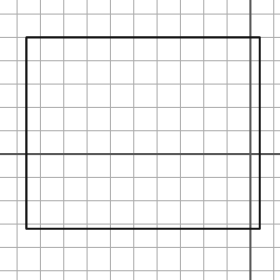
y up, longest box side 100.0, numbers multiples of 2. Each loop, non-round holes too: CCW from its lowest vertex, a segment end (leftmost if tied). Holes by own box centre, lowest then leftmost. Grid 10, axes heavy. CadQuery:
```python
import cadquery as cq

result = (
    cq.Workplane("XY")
    .moveTo(-96.0, -32.0)
    .lineTo(4.0, -32.0)
    .lineTo(4.0, 50.0)
    .lineTo(-96.0, 50.0)
    .close()
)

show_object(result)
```